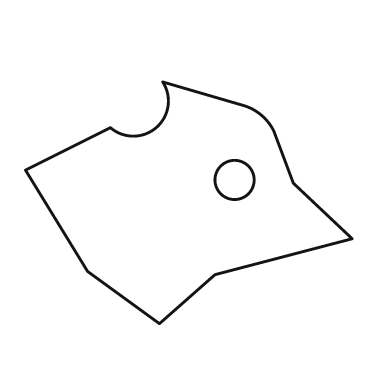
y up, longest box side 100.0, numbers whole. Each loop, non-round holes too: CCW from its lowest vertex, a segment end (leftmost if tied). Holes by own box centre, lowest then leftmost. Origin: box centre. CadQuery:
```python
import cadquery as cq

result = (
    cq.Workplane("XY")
    .moveTo(-9.0, -37.0)
    .lineTo(8.0, -22.0)
    .lineTo(50.0, -11.0)
    .lineTo(32.0, 6.0)
    .lineTo(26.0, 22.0)
    .threePointArc((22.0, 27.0), (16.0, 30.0))
    .lineTo(-8.0, 37.0)
    .threePointArc((-10.0, 23.0), (-24.0, 23.0))
    .lineTo(-50.0, 10.0)
    .lineTo(-31.0, -21.0)
    .close()
    .moveTo(14.0, 7.0)
    .circle(6.0)
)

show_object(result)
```